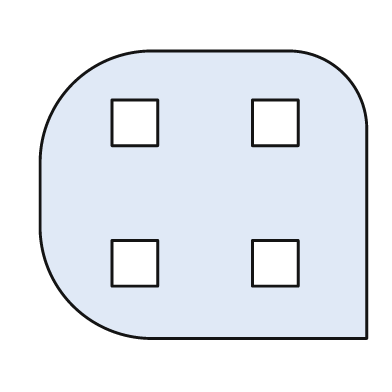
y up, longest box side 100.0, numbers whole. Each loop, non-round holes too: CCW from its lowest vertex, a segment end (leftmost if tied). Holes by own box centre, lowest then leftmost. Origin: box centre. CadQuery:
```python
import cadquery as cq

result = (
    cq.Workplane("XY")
    .moveTo(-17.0, -44.0)
    .lineTo(50.0, -44.0)
    .lineTo(50.0, 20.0)
    .threePointArc((43.0, 37.0), (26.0, 44.0))
    .lineTo(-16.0, 44.0)
    .threePointArc((-40.0, 34.0), (-50.0, 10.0))
    .lineTo(-50.0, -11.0)
    .threePointArc((-40.0, -34.0), (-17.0, -44.0))
    .close()
    .moveTo(-28.0, -28.0)
    .lineTo(-14.0, -28.0)
    .lineTo(-14.0, -14.0)
    .lineTo(-28.0, -14.0)
    .close()
    .moveTo(15.0, -28.0)
    .lineTo(29.0, -28.0)
    .lineTo(29.0, -14.0)
    .lineTo(15.0, -14.0)
    .close()
    .moveTo(-28.0, 15.0)
    .lineTo(-14.0, 15.0)
    .lineTo(-14.0, 29.0)
    .lineTo(-28.0, 29.0)
    .close()
    .moveTo(15.0, 15.0)
    .lineTo(29.0, 15.0)
    .lineTo(29.0, 29.0)
    .lineTo(15.0, 29.0)
    .close()
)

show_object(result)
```